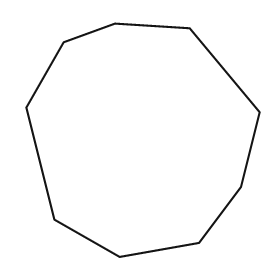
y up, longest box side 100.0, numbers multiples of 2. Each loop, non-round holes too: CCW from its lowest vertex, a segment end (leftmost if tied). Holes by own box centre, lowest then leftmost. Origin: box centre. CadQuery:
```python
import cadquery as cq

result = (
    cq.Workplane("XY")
    .moveTo(-10.0, -50.0)
    .lineTo(24.0, -44.0)
    .lineTo(42.0, -20.0)
    .lineTo(50.0, 12.0)
    .lineTo(20.0, 48.0)
    .lineTo(-12.0, 50.0)
    .lineTo(-34.0, 42.0)
    .lineTo(-50.0, 14.0)
    .lineTo(-38.0, -34.0)
    .close()
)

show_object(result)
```